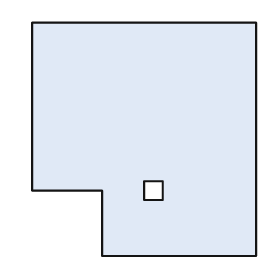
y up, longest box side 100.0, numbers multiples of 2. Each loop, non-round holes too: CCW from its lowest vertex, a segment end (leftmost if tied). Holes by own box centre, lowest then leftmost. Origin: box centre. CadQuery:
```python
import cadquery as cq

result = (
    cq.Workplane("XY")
    .moveTo(-18.0, -50.0)
    .lineTo(48.0, -50.0)
    .lineTo(48.0, 50.0)
    .lineTo(-48.0, 50.0)
    .lineTo(-48.0, -22.0)
    .lineTo(-18.0, -22.0)
    .close()
    .moveTo(0.0, -26.0)
    .lineTo(8.0, -26.0)
    .lineTo(8.0, -18.0)
    .lineTo(0.0, -18.0)
    .close()
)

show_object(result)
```